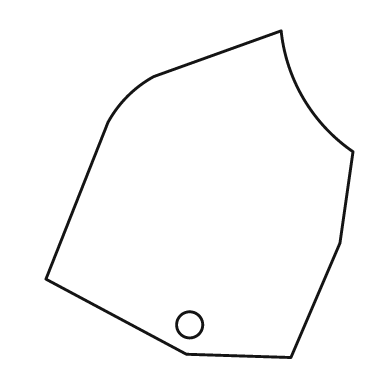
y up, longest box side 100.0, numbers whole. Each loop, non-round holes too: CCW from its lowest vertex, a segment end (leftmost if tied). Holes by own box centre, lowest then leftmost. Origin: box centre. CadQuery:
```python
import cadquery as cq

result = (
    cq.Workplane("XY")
    .moveTo(28.0, -50.0)
    .lineTo(43.0, -15.0)
    .lineTo(47.0, 13.0)
    .threePointArc((32.0, 29.0), (25.0, 50.0))
    .lineTo(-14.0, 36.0)
    .threePointArc((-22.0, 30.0), (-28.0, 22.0))
    .lineTo(-47.0, -26.0)
    .lineTo(-4.0, -49.0)
    .close()
    .moveTo(-3.0, -40.0)
    .circle(4.0)
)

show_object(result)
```